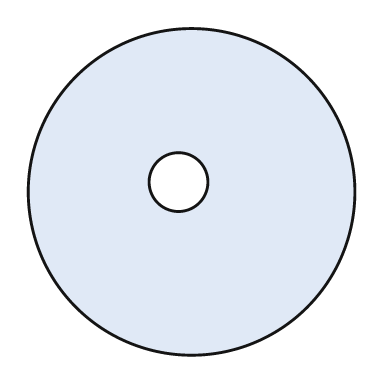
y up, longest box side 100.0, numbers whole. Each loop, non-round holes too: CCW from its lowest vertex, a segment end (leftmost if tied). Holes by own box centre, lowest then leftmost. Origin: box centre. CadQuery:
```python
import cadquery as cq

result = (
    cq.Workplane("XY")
    .moveTo(0.0, 0.0)
    .circle(50.0)
    .moveTo(-4.0, 3.0)
    .circle(9.0)
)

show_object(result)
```